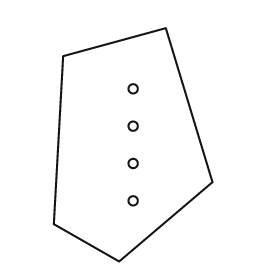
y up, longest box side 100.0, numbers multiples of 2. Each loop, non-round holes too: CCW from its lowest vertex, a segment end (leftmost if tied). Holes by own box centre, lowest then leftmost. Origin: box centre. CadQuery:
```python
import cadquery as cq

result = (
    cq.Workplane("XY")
    .moveTo(-6.0, -50.0)
    .lineTo(34.0, -16.0)
    .lineTo(14.0, 50.0)
    .lineTo(-30.0, 38.0)
    .lineTo(-34.0, -34.0)
    .close()
    .moveTo(0.0, -24.0)
    .circle(2.0)
    .moveTo(0.0, -8.0)
    .circle(2.0)
    .moveTo(0.0, 8.0)
    .circle(2.0)
    .moveTo(0.0, 24.0)
    .circle(2.0)
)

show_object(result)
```